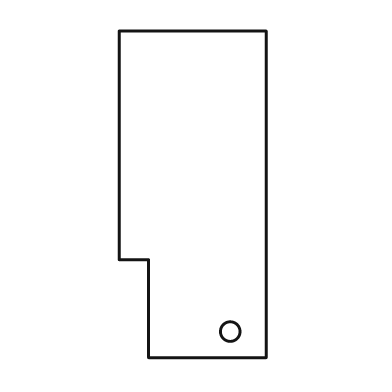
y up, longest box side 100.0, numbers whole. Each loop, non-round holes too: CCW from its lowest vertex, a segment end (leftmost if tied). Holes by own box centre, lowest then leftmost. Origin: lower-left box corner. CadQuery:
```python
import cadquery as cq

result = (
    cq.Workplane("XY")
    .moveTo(9.0, 0.0)
    .lineTo(45.0, 0.0)
    .lineTo(45.0, 100.0)
    .lineTo(0.0, 100.0)
    .lineTo(0.0, 30.0)
    .lineTo(9.0, 30.0)
    .close()
    .moveTo(34.0, 8.0)
    .circle(3.0)
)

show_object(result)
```